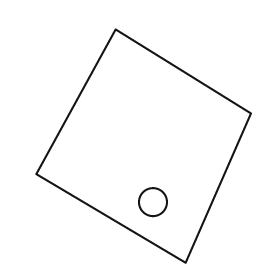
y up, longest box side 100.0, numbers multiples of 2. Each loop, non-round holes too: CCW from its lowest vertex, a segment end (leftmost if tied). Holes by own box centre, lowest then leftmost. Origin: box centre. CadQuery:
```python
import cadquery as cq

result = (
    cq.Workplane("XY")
    .moveTo(18.0, -50.0)
    .lineTo(46.0, 14.0)
    .lineTo(-12.0, 50.0)
    .lineTo(-46.0, -12.0)
    .close()
    .moveTo(4.0, -24.0)
    .circle(6.0)
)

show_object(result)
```